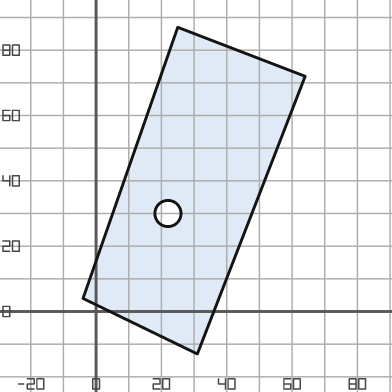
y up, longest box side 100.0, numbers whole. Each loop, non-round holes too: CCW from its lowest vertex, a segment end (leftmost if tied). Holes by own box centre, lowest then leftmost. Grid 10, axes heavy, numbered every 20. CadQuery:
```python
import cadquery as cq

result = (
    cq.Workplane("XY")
    .moveTo(31.0, -13.0)
    .lineTo(64.0, 72.0)
    .lineTo(25.0, 87.0)
    .lineTo(-4.0, 4.0)
    .close()
    .moveTo(22.0, 30.0)
    .circle(4.0)
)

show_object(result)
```